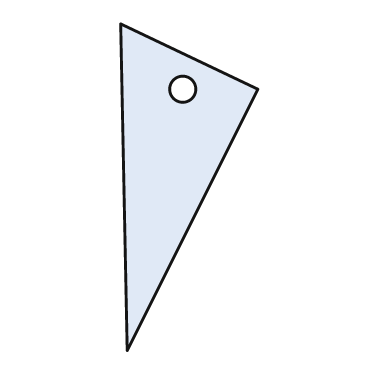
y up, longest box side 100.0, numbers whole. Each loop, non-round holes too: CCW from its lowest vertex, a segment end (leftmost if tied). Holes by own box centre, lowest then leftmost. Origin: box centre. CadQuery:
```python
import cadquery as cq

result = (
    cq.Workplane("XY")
    .moveTo(-19.0, -50.0)
    .lineTo(21.0, 30.0)
    .lineTo(-21.0, 50.0)
    .close()
    .moveTo(-2.0, 30.0)
    .circle(4.0)
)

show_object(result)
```